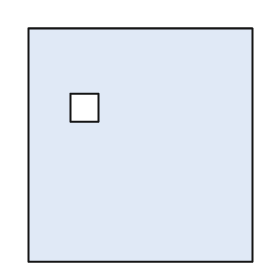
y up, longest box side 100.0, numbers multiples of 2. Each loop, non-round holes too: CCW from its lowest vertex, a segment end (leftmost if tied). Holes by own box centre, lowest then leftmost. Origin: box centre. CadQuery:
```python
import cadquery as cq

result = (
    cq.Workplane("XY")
    .moveTo(-48.0, -50.0)
    .lineTo(48.0, -50.0)
    .lineTo(48.0, 50.0)
    .lineTo(-48.0, 50.0)
    .close()
    .moveTo(-30.0, 10.0)
    .lineTo(-18.0, 10.0)
    .lineTo(-18.0, 22.0)
    .lineTo(-30.0, 22.0)
    .close()
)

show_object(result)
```